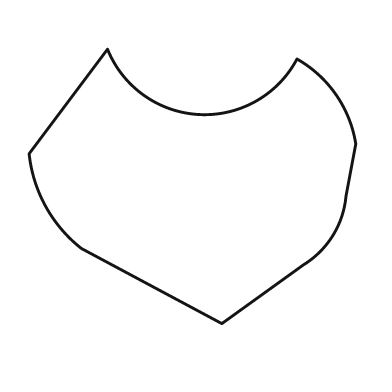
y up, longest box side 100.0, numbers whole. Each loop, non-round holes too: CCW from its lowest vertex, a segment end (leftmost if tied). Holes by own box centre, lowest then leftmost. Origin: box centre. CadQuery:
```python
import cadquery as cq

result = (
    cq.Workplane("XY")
    .moveTo(9.0, -42.0)
    .lineTo(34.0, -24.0)
    .threePointArc((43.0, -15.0), (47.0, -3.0))
    .lineTo(50.0, 13.0)
    .threePointArc((44.0, 28.0), (32.0, 39.0))
    .threePointArc((2.0, 22.0), (-26.0, 42.0))
    .lineTo(-50.0, 10.0)
    .threePointArc((-45.0, -6.0), (-34.0, -19.0))
    .close()
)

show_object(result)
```